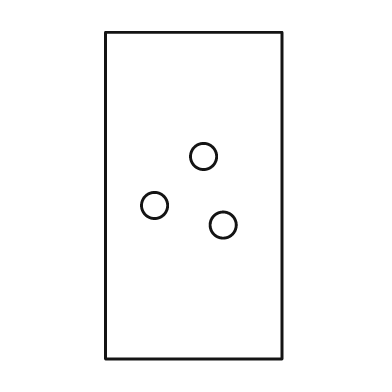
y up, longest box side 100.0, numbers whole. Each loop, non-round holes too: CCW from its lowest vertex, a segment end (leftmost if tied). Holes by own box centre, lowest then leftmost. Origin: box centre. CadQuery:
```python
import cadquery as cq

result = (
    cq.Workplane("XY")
    .moveTo(-27.0, -50.0)
    .lineTo(27.0, -50.0)
    .lineTo(27.0, 50.0)
    .lineTo(-27.0, 50.0)
    .close()
    .moveTo(9.0, -9.0)
    .circle(4.0)
    .moveTo(-12.0, -3.0)
    .circle(4.0)
    .moveTo(3.0, 12.0)
    .circle(4.0)
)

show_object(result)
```